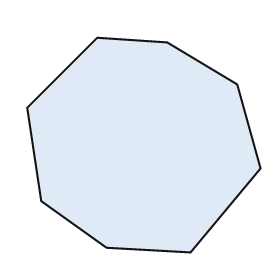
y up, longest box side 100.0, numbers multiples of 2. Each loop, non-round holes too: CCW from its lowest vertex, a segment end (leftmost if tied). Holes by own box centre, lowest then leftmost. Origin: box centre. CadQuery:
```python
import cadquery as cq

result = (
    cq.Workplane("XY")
    .moveTo(20.0, -46.0)
    .lineTo(50.0, -10.0)
    .lineTo(40.0, 26.0)
    .lineTo(10.0, 44.0)
    .lineTo(-20.0, 46.0)
    .lineTo(-50.0, 16.0)
    .lineTo(-44.0, -24.0)
    .lineTo(-16.0, -44.0)
    .close()
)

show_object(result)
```